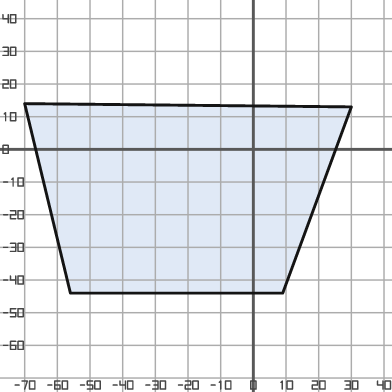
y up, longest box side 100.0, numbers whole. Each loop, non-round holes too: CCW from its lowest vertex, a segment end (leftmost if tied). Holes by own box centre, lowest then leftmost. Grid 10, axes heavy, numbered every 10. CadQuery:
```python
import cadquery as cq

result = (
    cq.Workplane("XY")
    .moveTo(-56.0, -44.0)
    .lineTo(9.0, -44.0)
    .lineTo(30.0, 13.0)
    .lineTo(-70.0, 14.0)
    .close()
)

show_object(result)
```